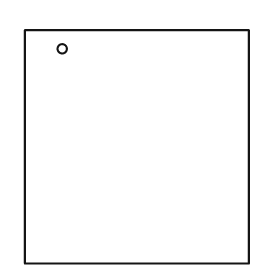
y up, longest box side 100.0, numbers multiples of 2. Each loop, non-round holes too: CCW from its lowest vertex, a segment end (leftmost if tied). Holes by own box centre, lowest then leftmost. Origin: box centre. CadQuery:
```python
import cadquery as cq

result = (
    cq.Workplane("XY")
    .moveTo(-48.0, -50.0)
    .lineTo(48.0, -50.0)
    .lineTo(48.0, 50.0)
    .lineTo(-48.0, 50.0)
    .close()
    .moveTo(-32.0, 42.0)
    .circle(2.0)
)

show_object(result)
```